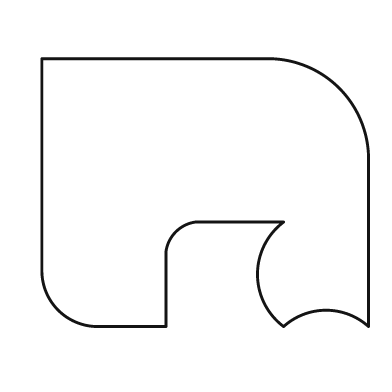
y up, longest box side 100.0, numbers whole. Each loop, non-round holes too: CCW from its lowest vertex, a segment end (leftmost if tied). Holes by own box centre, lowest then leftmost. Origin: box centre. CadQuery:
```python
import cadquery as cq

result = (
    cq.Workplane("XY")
    .moveTo(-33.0, -41.0)
    .lineTo(-12.0, -41.0)
    .lineTo(-12.0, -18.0)
    .threePointArc((-9.0, -12.0), (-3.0, -9.0))
    .lineTo(24.0, -9.0)
    .threePointArc((16.0, -25.0), (24.0, -41.0))
    .threePointArc((37.0, -36.0), (50.0, -41.0))
    .lineTo(50.0, 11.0)
    .threePointArc((41.0, 32.0), (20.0, 41.0))
    .lineTo(-50.0, 41.0)
    .lineTo(-50.0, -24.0)
    .threePointArc((-45.0, -36.0), (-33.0, -41.0))
    .close()
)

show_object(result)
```